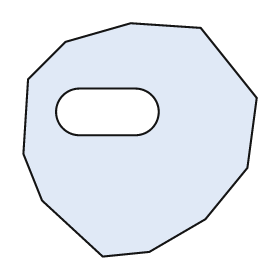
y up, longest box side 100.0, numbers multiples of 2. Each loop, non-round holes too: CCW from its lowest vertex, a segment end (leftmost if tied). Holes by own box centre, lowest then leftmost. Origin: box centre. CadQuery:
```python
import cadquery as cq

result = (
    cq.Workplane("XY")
    .moveTo(-16.0, -50.0)
    .lineTo(4.0, -48.0)
    .lineTo(28.0, -34.0)
    .lineTo(46.0, -12.0)
    .lineTo(50.0, 18.0)
    .lineTo(26.0, 48.0)
    .lineTo(-4.0, 50.0)
    .lineTo(-32.0, 42.0)
    .lineTo(-48.0, 26.0)
    .lineTo(-50.0, -6.0)
    .lineTo(-42.0, -26.0)
    .close()
    .moveTo(-26.0, 2.0)
    .lineTo(-2.0, 2.0)
    .threePointArc((8.0, 12.0), (-2.0, 22.0))
    .lineTo(-26.0, 22.0)
    .threePointArc((-36.0, 12.0), (-26.0, 2.0))
    .close()
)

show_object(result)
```